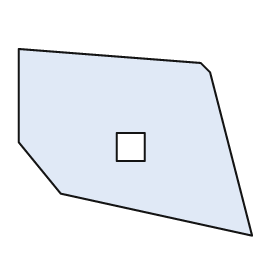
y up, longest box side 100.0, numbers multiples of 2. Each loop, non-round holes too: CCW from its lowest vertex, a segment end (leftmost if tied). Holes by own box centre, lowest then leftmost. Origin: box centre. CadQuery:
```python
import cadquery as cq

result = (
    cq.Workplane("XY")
    .moveTo(50.0, -40.0)
    .lineTo(32.0, 30.0)
    .lineTo(28.0, 34.0)
    .lineTo(-50.0, 40.0)
    .lineTo(-50.0, 0.0)
    .lineTo(-32.0, -22.0)
    .close()
    .moveTo(-8.0, -8.0)
    .lineTo(4.0, -8.0)
    .lineTo(4.0, 4.0)
    .lineTo(-8.0, 4.0)
    .close()
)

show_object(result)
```